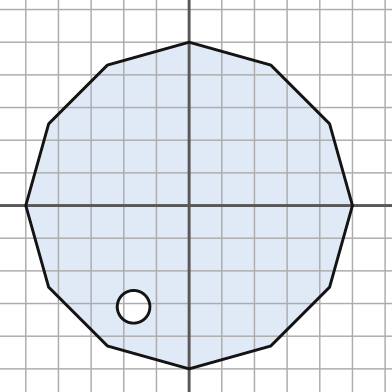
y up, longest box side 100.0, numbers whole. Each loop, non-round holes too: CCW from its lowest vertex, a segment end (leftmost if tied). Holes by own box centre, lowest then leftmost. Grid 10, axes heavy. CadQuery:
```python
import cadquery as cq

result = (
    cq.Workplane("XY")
    .moveTo(0.0, -50.0)
    .lineTo(25.0, -43.0)
    .lineTo(43.0, -25.0)
    .lineTo(50.0, 0.0)
    .lineTo(43.0, 25.0)
    .lineTo(25.0, 43.0)
    .lineTo(0.0, 50.0)
    .lineTo(-25.0, 43.0)
    .lineTo(-43.0, 25.0)
    .lineTo(-50.0, 0.0)
    .lineTo(-43.0, -25.0)
    .lineTo(-25.0, -43.0)
    .close()
    .moveTo(-17.0, -31.0)
    .circle(5.0)
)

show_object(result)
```